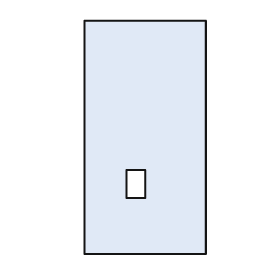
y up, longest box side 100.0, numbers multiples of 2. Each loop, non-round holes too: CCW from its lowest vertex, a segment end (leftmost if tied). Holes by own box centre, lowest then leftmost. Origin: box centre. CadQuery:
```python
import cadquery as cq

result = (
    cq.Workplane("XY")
    .moveTo(-26.0, -50.0)
    .lineTo(26.0, -50.0)
    .lineTo(26.0, 50.0)
    .lineTo(-26.0, 50.0)
    .close()
    .moveTo(-8.0, -26.0)
    .lineTo(0.0, -26.0)
    .lineTo(0.0, -14.0)
    .lineTo(-8.0, -14.0)
    .close()
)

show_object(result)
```